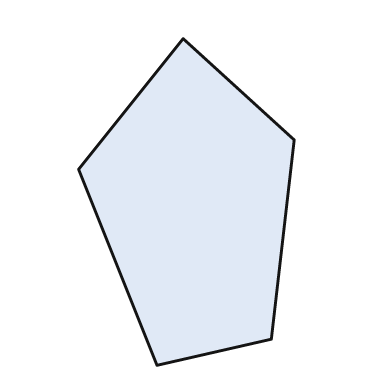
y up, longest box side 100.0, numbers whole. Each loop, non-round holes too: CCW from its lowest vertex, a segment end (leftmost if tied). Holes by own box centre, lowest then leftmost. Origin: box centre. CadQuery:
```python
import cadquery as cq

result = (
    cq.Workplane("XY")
    .moveTo(-9.0, -50.0)
    .lineTo(26.0, -42.0)
    .lineTo(33.0, 19.0)
    .lineTo(-1.0, 50.0)
    .lineTo(-33.0, 10.0)
    .close()
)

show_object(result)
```